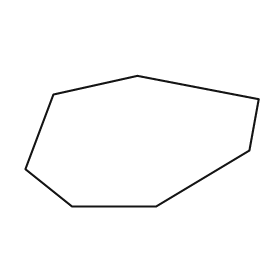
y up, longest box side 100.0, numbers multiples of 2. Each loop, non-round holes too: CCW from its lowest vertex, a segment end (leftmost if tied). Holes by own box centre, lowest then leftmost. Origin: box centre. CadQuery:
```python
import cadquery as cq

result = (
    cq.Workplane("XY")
    .moveTo(-30.0, -28.0)
    .lineTo(6.0, -28.0)
    .lineTo(46.0, -4.0)
    .lineTo(50.0, 18.0)
    .lineTo(-2.0, 28.0)
    .lineTo(-38.0, 20.0)
    .lineTo(-50.0, -12.0)
    .close()
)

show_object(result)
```